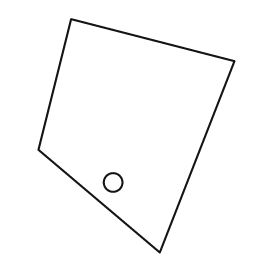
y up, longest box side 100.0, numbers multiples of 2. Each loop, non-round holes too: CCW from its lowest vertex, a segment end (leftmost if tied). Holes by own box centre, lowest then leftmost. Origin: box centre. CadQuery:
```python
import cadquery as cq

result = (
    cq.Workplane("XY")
    .moveTo(10.0, -50.0)
    .lineTo(42.0, 32.0)
    .lineTo(-28.0, 50.0)
    .lineTo(-42.0, -6.0)
    .close()
    .moveTo(-10.0, -20.0)
    .circle(4.0)
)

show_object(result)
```